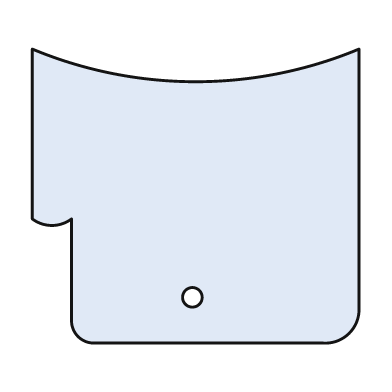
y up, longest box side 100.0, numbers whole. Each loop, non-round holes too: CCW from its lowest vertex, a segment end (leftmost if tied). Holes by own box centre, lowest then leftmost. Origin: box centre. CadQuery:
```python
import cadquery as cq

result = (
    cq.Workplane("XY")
    .moveTo(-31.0, -45.0)
    .lineTo(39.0, -45.0)
    .threePointArc((47.0, -42.0), (50.0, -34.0))
    .lineTo(50.0, 45.0)
    .threePointArc((0.0, 35.0), (-50.0, 45.0))
    .lineTo(-50.0, -7.0)
    .threePointArc((-44.0, -9.0), (-38.0, -7.0))
    .lineTo(-38.0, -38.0)
    .threePointArc((-36.0, -43.0), (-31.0, -45.0))
    .close()
    .moveTo(-1.0, -31.0)
    .circle(3.0)
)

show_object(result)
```